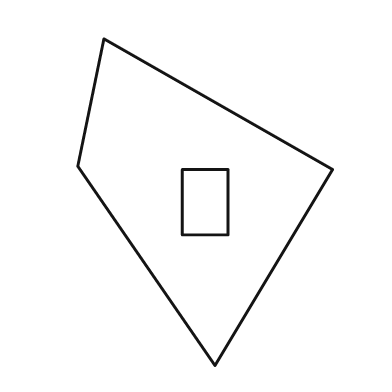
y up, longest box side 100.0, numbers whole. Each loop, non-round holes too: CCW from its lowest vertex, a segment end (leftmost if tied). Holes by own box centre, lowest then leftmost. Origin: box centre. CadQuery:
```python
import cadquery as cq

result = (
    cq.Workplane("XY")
    .moveTo(3.0, -50.0)
    .lineTo(39.0, 10.0)
    .lineTo(-31.0, 50.0)
    .lineTo(-39.0, 11.0)
    .close()
    .moveTo(-7.0, -10.0)
    .lineTo(7.0, -10.0)
    .lineTo(7.0, 10.0)
    .lineTo(-7.0, 10.0)
    .close()
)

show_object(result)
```